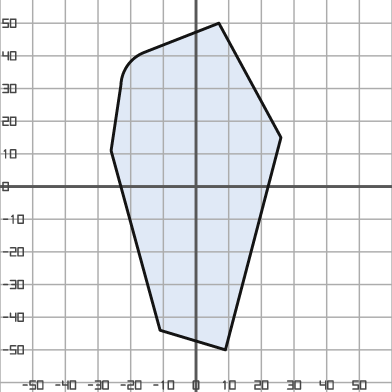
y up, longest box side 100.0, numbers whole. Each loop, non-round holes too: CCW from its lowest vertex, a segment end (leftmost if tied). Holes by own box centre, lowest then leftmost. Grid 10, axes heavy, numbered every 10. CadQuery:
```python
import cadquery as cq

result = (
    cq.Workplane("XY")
    .moveTo(9.0, -50.0)
    .lineTo(26.0, 15.0)
    .lineTo(7.0, 50.0)
    .lineTo(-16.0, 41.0)
    .threePointArc((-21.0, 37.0), (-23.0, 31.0))
    .lineTo(-26.0, 11.0)
    .lineTo(-11.0, -44.0)
    .close()
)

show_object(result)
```